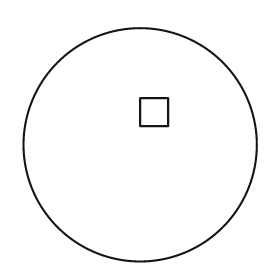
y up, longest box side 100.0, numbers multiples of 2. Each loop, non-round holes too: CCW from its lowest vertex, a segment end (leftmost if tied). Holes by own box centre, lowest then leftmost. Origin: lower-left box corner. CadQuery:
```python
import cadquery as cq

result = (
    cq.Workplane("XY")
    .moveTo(50.0, 50.0)
    .circle(50.0)
    .moveTo(50.0, 58.0)
    .lineTo(62.0, 58.0)
    .lineTo(62.0, 70.0)
    .lineTo(50.0, 70.0)
    .close()
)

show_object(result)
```